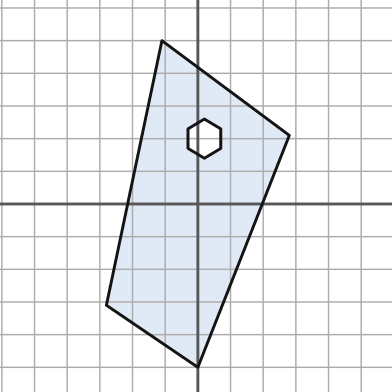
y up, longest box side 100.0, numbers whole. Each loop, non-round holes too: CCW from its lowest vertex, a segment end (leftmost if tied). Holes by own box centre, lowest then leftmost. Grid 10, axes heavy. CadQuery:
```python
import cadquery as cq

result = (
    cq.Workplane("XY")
    .moveTo(0.0, -50.0)
    .lineTo(28.0, 21.0)
    .lineTo(-11.0, 50.0)
    .lineTo(-28.0, -31.0)
    .close()
    .moveTo(2.0, 14.0)
    .lineTo(7.0, 17.0)
    .lineTo(7.0, 23.0)
    .lineTo(2.0, 26.0)
    .lineTo(-3.0, 23.0)
    .lineTo(-3.0, 17.0)
    .close()
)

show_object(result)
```